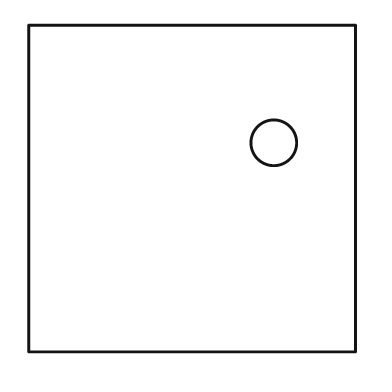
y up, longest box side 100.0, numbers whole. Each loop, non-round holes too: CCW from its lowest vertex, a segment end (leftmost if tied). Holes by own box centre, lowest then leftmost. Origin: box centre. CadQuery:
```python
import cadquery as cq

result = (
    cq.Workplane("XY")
    .moveTo(-50.0, -50.0)
    .lineTo(50.0, -50.0)
    .lineTo(50.0, 50.0)
    .lineTo(-50.0, 50.0)
    .close()
    .moveTo(25.0, 14.0)
    .circle(7.0)
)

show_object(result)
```